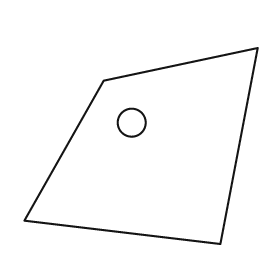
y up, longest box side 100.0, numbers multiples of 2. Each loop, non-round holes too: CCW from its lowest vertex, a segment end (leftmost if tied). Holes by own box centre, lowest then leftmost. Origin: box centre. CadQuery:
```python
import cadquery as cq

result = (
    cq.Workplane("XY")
    .moveTo(34.0, -42.0)
    .lineTo(50.0, 42.0)
    .lineTo(-16.0, 28.0)
    .lineTo(-50.0, -32.0)
    .close()
    .moveTo(-4.0, 10.0)
    .circle(6.0)
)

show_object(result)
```